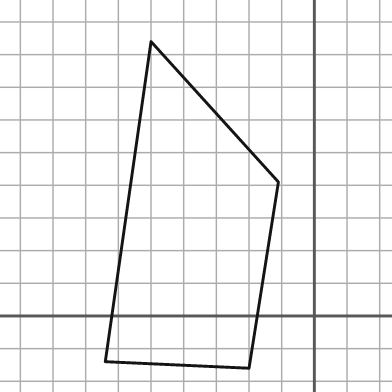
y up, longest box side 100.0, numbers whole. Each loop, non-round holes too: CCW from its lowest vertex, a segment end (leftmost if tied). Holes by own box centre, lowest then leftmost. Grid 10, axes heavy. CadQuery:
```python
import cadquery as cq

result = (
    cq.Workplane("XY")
    .moveTo(-20.0, -16.0)
    .lineTo(-11.0, 41.0)
    .lineTo(-50.0, 84.0)
    .lineTo(-64.0, -14.0)
    .close()
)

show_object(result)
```